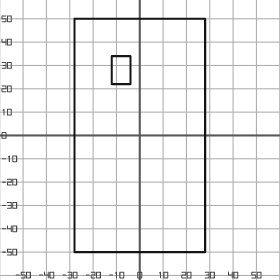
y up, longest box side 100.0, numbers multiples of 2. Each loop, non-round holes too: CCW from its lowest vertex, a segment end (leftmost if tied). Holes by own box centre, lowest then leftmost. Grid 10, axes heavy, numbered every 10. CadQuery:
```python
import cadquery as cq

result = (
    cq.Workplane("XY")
    .moveTo(-28.0, -50.0)
    .lineTo(28.0, -50.0)
    .lineTo(28.0, 50.0)
    .lineTo(-28.0, 50.0)
    .close()
    .moveTo(-12.0, 22.0)
    .lineTo(-4.0, 22.0)
    .lineTo(-4.0, 34.0)
    .lineTo(-12.0, 34.0)
    .close()
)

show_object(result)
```